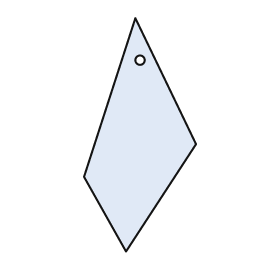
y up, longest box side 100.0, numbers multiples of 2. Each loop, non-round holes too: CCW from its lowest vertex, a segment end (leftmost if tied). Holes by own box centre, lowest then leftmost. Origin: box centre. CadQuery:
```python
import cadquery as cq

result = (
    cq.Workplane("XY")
    .moveTo(-6.0, -50.0)
    .lineTo(24.0, -4.0)
    .lineTo(-2.0, 50.0)
    .lineTo(-24.0, -18.0)
    .close()
    .moveTo(0.0, 32.0)
    .circle(2.0)
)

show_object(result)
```